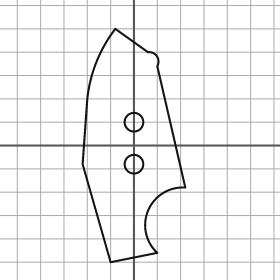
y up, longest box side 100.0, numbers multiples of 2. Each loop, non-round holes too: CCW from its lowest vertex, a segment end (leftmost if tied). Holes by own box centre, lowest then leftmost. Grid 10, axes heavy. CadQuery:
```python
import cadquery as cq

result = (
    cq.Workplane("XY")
    .moveTo(-10.0, -50.0)
    .lineTo(10.0, -46.0)
    .threePointArc((6.0, -28.0), (22.0, -18.0))
    .lineTo(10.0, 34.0)
    .threePointArc((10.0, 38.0), (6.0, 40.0))
    .lineTo(-8.0, 50.0)
    .threePointArc((-16.0, 36.0), (-20.0, 20.0))
    .lineTo(-22.0, -8.0)
    .close()
    .moveTo(0.0, -8.0)
    .circle(4.0)
    .moveTo(0.0, 10.0)
    .circle(4.0)
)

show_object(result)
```